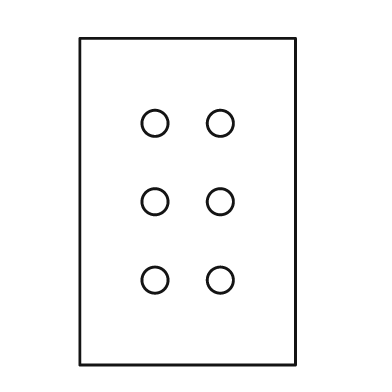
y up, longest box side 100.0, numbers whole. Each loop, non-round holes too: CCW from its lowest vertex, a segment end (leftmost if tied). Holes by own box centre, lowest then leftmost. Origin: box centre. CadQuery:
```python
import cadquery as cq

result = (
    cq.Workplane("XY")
    .moveTo(-33.0, -50.0)
    .lineTo(33.0, -50.0)
    .lineTo(33.0, 50.0)
    .lineTo(-33.0, 50.0)
    .close()
    .moveTo(-10.0, -24.0)
    .circle(4.0)
    .moveTo(10.0, -24.0)
    .circle(4.0)
    .moveTo(-10.0, 0.0)
    .circle(4.0)
    .moveTo(10.0, 0.0)
    .circle(4.0)
    .moveTo(-10.0, 24.0)
    .circle(4.0)
    .moveTo(10.0, 24.0)
    .circle(4.0)
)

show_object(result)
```